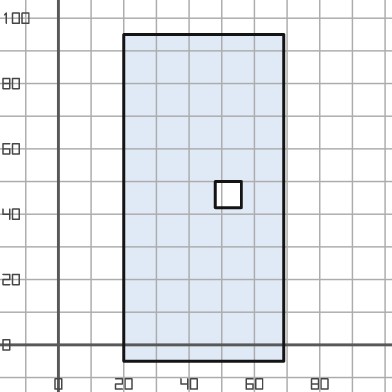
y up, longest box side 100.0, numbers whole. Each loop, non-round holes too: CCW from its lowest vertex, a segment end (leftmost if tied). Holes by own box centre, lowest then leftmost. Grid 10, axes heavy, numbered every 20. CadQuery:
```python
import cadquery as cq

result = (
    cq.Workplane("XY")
    .moveTo(20.0, -5.0)
    .lineTo(69.0, -5.0)
    .lineTo(69.0, 95.0)
    .lineTo(20.0, 95.0)
    .close()
    .moveTo(48.0, 42.0)
    .lineTo(56.0, 42.0)
    .lineTo(56.0, 50.0)
    .lineTo(48.0, 50.0)
    .close()
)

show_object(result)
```